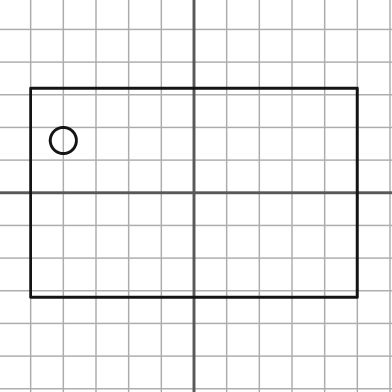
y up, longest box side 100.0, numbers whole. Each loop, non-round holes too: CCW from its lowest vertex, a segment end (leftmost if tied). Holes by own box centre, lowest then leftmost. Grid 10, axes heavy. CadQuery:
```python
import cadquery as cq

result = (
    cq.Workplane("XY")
    .moveTo(-50.0, -32.0)
    .lineTo(50.0, -32.0)
    .lineTo(50.0, 32.0)
    .lineTo(-50.0, 32.0)
    .close()
    .moveTo(-40.0, 16.0)
    .circle(4.0)
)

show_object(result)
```